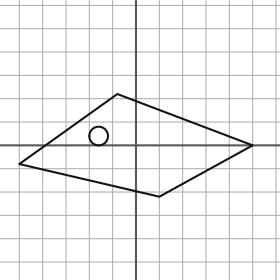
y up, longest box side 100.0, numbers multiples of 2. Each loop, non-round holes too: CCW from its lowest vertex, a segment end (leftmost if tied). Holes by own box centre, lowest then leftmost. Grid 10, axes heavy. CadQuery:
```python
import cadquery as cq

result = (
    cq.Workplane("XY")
    .moveTo(10.0, -22.0)
    .lineTo(50.0, 0.0)
    .lineTo(-8.0, 22.0)
    .lineTo(-50.0, -8.0)
    .close()
    .moveTo(-16.0, 4.0)
    .circle(4.0)
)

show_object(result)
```